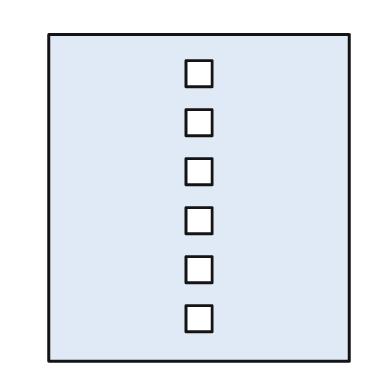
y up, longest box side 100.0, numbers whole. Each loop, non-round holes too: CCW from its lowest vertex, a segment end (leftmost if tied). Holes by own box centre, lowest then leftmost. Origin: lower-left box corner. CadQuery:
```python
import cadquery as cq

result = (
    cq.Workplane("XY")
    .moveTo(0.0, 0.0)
    .lineTo(92.0, 0.0)
    .lineTo(92.0, 100.0)
    .lineTo(0.0, 100.0)
    .close()
    .moveTo(42.0, 9.0)
    .lineTo(50.0, 9.0)
    .lineTo(50.0, 17.0)
    .lineTo(42.0, 17.0)
    .close()
    .moveTo(42.0, 24.0)
    .lineTo(50.0, 24.0)
    .lineTo(50.0, 32.0)
    .lineTo(42.0, 32.0)
    .close()
    .moveTo(42.0, 39.0)
    .lineTo(50.0, 39.0)
    .lineTo(50.0, 47.0)
    .lineTo(42.0, 47.0)
    .close()
    .moveTo(42.0, 54.0)
    .lineTo(50.0, 54.0)
    .lineTo(50.0, 62.0)
    .lineTo(42.0, 62.0)
    .close()
    .moveTo(42.0, 69.0)
    .lineTo(50.0, 69.0)
    .lineTo(50.0, 77.0)
    .lineTo(42.0, 77.0)
    .close()
    .moveTo(42.0, 84.0)
    .lineTo(50.0, 84.0)
    .lineTo(50.0, 92.0)
    .lineTo(42.0, 92.0)
    .close()
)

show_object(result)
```